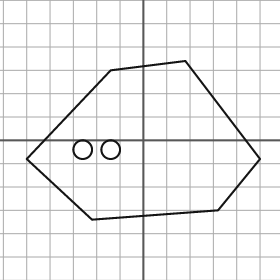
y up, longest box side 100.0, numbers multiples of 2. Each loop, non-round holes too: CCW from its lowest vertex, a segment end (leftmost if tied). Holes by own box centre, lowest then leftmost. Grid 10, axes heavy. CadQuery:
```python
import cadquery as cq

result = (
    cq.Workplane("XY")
    .moveTo(-22.0, -34.0)
    .lineTo(32.0, -30.0)
    .lineTo(50.0, -8.0)
    .lineTo(18.0, 34.0)
    .lineTo(-14.0, 30.0)
    .lineTo(-50.0, -8.0)
    .close()
    .moveTo(-26.0, -4.0)
    .circle(4.0)
    .moveTo(-14.0, -4.0)
    .circle(4.0)
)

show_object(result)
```